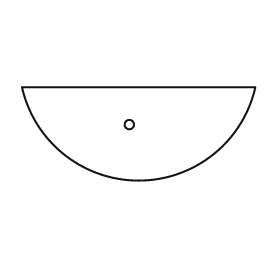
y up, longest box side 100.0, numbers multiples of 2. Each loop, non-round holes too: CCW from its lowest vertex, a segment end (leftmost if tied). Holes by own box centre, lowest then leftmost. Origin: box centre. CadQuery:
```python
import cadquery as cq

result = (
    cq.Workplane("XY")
    .moveTo(-50.0, 20.0)
    .threePointArc((0.0, -20.0), (50.0, 20.0))
    .close()
    .moveTo(-4.0, 4.0)
    .circle(2.0)
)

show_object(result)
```